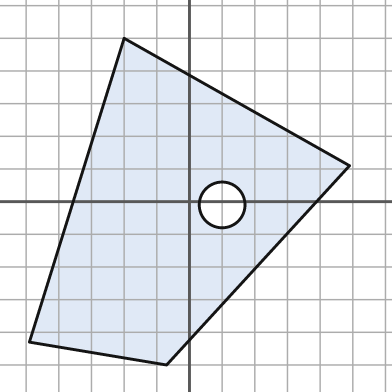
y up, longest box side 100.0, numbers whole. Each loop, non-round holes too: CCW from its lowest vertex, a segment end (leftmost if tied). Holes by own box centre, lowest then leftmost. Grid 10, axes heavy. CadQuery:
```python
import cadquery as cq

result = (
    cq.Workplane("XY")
    .moveTo(-7.0, -50.0)
    .lineTo(49.0, 11.0)
    .lineTo(-20.0, 50.0)
    .lineTo(-49.0, -43.0)
    .close()
    .moveTo(10.0, -1.0)
    .circle(7.0)
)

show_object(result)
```